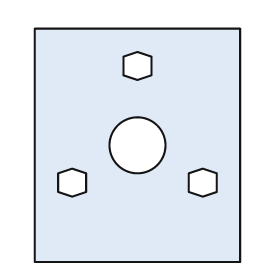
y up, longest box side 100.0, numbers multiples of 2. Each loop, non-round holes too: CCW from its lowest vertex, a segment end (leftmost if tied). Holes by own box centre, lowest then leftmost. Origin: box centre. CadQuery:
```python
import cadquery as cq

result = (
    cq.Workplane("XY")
    .moveTo(-44.0, -50.0)
    .lineTo(44.0, -50.0)
    .lineTo(44.0, 50.0)
    .lineTo(-44.0, 50.0)
    .close()
    .moveTo(-28.0, -22.0)
    .lineTo(-22.0, -20.0)
    .lineTo(-22.0, -12.0)
    .lineTo(-28.0, -10.0)
    .lineTo(-34.0, -12.0)
    .lineTo(-34.0, -20.0)
    .close()
    .moveTo(28.0, -22.0)
    .lineTo(34.0, -20.0)
    .lineTo(34.0, -12.0)
    .lineTo(28.0, -10.0)
    .lineTo(22.0, -12.0)
    .lineTo(22.0, -20.0)
    .close()
    .moveTo(0.0, 0.0)
    .circle(12.0)
    .moveTo(0.0, 28.0)
    .lineTo(6.0, 30.0)
    .lineTo(6.0, 38.0)
    .lineTo(0.0, 40.0)
    .lineTo(-6.0, 38.0)
    .lineTo(-6.0, 30.0)
    .close()
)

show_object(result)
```